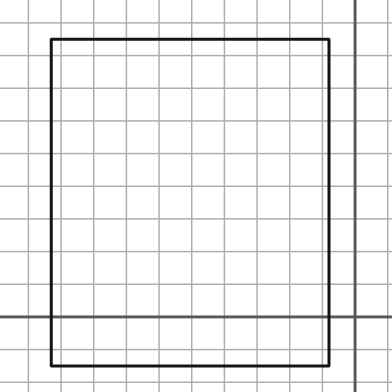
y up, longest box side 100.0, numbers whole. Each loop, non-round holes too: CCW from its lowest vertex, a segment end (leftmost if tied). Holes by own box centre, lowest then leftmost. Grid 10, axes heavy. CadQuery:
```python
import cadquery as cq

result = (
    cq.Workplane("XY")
    .moveTo(-93.0, -15.0)
    .lineTo(-8.0, -15.0)
    .lineTo(-8.0, 85.0)
    .lineTo(-93.0, 85.0)
    .close()
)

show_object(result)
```